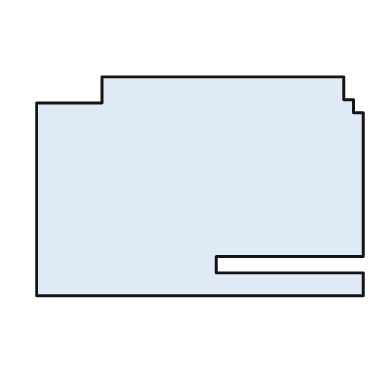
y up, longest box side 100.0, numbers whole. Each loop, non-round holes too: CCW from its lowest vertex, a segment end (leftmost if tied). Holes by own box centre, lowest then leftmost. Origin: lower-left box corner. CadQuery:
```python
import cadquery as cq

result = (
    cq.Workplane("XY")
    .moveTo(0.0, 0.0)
    .lineTo(100.0, 0.0)
    .lineTo(100.0, 7.0)
    .lineTo(55.0, 7.0)
    .lineTo(55.0, 12.0)
    .lineTo(100.0, 12.0)
    .lineTo(100.0, 56.0)
    .lineTo(97.0, 56.0)
    .lineTo(97.0, 60.0)
    .lineTo(94.0, 60.0)
    .lineTo(94.0, 67.0)
    .lineTo(20.0, 67.0)
    .lineTo(20.0, 59.0)
    .lineTo(0.0, 59.0)
    .close()
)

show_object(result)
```